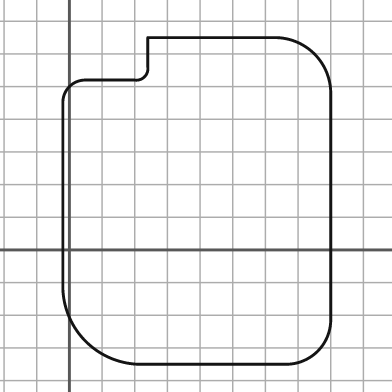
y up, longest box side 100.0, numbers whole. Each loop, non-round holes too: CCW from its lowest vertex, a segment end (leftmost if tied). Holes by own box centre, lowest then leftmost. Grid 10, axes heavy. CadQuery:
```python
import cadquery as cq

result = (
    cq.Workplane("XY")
    .moveTo(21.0, -35.0)
    .lineTo(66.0, -35.0)
    .threePointArc((76.0, -31.0), (80.0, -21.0))
    .lineTo(80.0, 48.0)
    .threePointArc((75.0, 60.0), (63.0, 65.0))
    .lineTo(24.0, 65.0)
    .lineTo(24.0, 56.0)
    .threePointArc((23.0, 53.0), (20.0, 52.0))
    .lineTo(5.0, 52.0)
    .threePointArc((0.0, 50.0), (-2.0, 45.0))
    .lineTo(-2.0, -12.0)
    .threePointArc((5.0, -28.0), (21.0, -35.0))
    .close()
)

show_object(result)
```